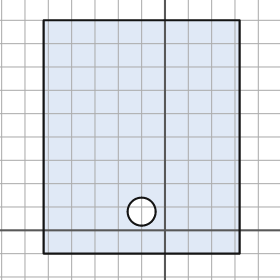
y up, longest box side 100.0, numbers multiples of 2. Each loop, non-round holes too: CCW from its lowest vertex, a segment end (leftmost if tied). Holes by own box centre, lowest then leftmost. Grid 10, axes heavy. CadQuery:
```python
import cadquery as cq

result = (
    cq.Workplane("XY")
    .moveTo(-52.0, -10.0)
    .lineTo(32.0, -10.0)
    .lineTo(32.0, 90.0)
    .lineTo(-52.0, 90.0)
    .close()
    .moveTo(-10.0, 8.0)
    .circle(6.0)
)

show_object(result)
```